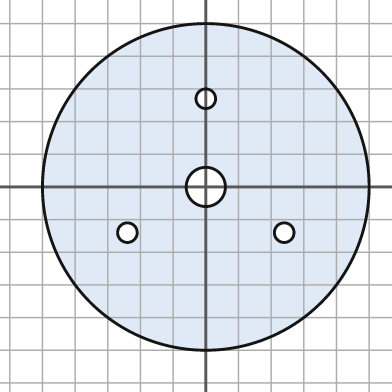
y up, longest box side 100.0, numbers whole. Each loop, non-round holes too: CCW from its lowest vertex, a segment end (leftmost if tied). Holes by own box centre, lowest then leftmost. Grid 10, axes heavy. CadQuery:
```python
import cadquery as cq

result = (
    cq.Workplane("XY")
    .moveTo(0.0, 0.0)
    .circle(50.0)
    .moveTo(-24.0, -14.0)
    .circle(3.0)
    .moveTo(24.0, -14.0)
    .circle(3.0)
    .moveTo(0.0, 0.0)
    .circle(6.0)
    .moveTo(0.0, 27.0)
    .circle(3.0)
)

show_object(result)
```